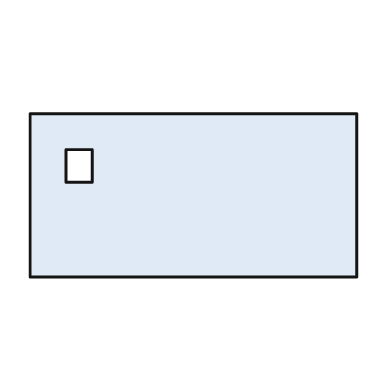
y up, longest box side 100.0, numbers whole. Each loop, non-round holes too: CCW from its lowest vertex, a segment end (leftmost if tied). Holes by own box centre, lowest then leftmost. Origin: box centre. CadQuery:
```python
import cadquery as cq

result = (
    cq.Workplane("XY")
    .moveTo(-50.0, -25.0)
    .lineTo(50.0, -25.0)
    .lineTo(50.0, 25.0)
    .lineTo(-50.0, 25.0)
    .close()
    .moveTo(-39.0, 4.0)
    .lineTo(-31.0, 4.0)
    .lineTo(-31.0, 14.0)
    .lineTo(-39.0, 14.0)
    .close()
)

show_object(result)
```